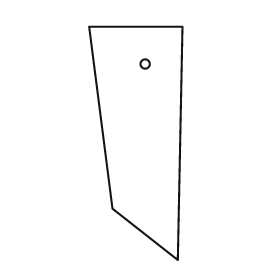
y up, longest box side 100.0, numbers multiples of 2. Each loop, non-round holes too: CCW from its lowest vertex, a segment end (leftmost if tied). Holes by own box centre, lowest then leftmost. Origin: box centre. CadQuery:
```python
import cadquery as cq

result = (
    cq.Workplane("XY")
    .moveTo(18.0, -50.0)
    .lineTo(20.0, 50.0)
    .lineTo(-20.0, 50.0)
    .lineTo(-10.0, -28.0)
    .close()
    .moveTo(4.0, 34.0)
    .circle(2.0)
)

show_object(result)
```